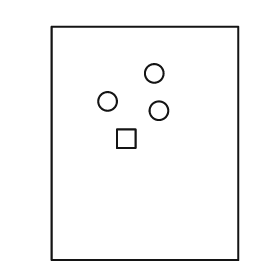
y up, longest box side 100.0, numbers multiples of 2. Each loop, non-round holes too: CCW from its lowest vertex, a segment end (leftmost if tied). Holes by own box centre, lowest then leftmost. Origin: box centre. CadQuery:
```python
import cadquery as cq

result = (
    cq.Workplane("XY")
    .moveTo(-40.0, -50.0)
    .lineTo(40.0, -50.0)
    .lineTo(40.0, 50.0)
    .lineTo(-40.0, 50.0)
    .close()
    .moveTo(-12.0, -2.0)
    .lineTo(-4.0, -2.0)
    .lineTo(-4.0, 6.0)
    .lineTo(-12.0, 6.0)
    .close()
    .moveTo(6.0, 14.0)
    .circle(4.0)
    .moveTo(-16.0, 18.0)
    .circle(4.0)
    .moveTo(4.0, 30.0)
    .circle(4.0)
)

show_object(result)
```